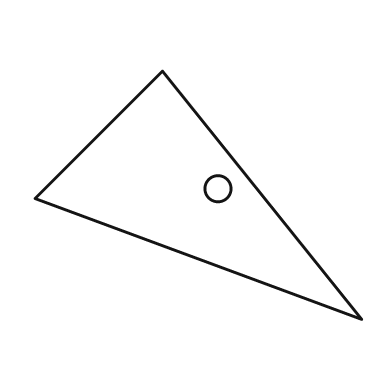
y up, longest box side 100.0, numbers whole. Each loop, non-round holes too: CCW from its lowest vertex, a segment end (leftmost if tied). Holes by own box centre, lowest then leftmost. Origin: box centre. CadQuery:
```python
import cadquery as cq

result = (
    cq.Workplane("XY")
    .moveTo(50.0, -38.0)
    .lineTo(-11.0, 38.0)
    .lineTo(-50.0, -1.0)
    .close()
    .moveTo(6.0, 2.0)
    .circle(4.0)
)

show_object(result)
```